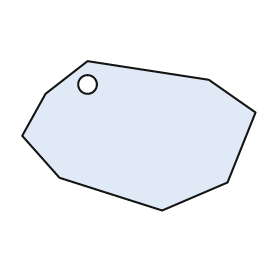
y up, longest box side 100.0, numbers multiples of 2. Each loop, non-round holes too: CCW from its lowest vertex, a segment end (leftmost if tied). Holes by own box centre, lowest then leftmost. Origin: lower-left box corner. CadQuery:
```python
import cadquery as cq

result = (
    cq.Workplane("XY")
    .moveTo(60.0, 0.0)
    .lineTo(88.0, 12.0)
    .lineTo(100.0, 42.0)
    .lineTo(80.0, 56.0)
    .lineTo(28.0, 64.0)
    .lineTo(10.0, 50.0)
    .lineTo(0.0, 32.0)
    .lineTo(16.0, 14.0)
    .close()
    .moveTo(28.0, 54.0)
    .circle(4.0)
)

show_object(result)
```